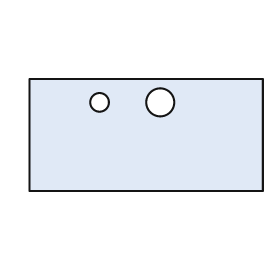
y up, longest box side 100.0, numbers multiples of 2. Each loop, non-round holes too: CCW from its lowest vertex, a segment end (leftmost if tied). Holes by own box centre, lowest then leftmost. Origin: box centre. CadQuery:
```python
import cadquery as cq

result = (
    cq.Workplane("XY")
    .moveTo(-50.0, -24.0)
    .lineTo(50.0, -24.0)
    .lineTo(50.0, 24.0)
    .lineTo(-50.0, 24.0)
    .close()
    .moveTo(-20.0, 14.0)
    .circle(4.0)
    .moveTo(6.0, 14.0)
    .circle(6.0)
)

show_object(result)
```